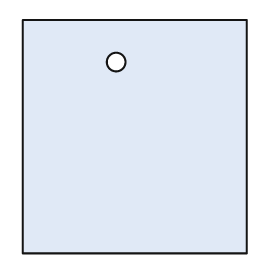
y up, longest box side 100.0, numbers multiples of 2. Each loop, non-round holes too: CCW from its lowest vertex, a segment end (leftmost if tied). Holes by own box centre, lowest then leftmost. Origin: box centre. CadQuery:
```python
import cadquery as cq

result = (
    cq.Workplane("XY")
    .moveTo(-48.0, -50.0)
    .lineTo(48.0, -50.0)
    .lineTo(48.0, 50.0)
    .lineTo(-48.0, 50.0)
    .close()
    .moveTo(-8.0, 32.0)
    .circle(4.0)
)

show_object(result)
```